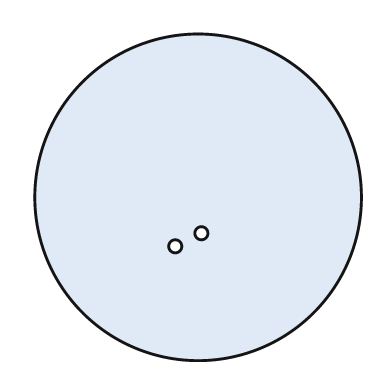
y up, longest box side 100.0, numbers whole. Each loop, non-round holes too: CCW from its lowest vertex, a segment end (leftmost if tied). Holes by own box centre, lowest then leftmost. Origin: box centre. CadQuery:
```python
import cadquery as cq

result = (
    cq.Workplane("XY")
    .moveTo(0.0, 0.0)
    .circle(50.0)
    .moveTo(-7.0, -15.0)
    .circle(2.0)
    .moveTo(1.0, -11.0)
    .circle(2.0)
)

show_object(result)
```